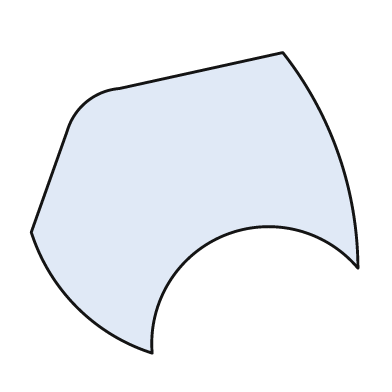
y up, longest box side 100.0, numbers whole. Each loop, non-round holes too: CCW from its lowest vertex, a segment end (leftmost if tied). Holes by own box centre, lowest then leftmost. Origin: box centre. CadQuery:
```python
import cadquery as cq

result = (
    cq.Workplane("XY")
    .moveTo(-13.0, -46.0)
    .threePointArc((9.0, -10.0), (50.0, -20.0))
    .threePointArc((44.0, 15.0), (27.0, 46.0))
    .lineTo(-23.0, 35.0)
    .threePointArc((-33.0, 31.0), (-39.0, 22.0))
    .lineTo(-50.0, -9.0)
    .threePointArc((-36.0, -32.0), (-13.0, -46.0))
    .close()
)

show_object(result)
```